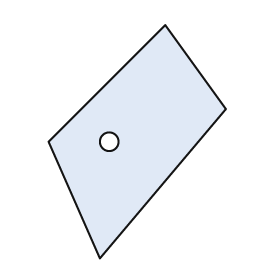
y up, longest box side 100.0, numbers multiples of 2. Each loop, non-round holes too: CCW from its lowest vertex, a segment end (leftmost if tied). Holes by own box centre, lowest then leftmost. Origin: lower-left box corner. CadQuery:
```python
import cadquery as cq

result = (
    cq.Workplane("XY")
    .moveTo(22.0, 0.0)
    .lineTo(76.0, 64.0)
    .lineTo(50.0, 100.0)
    .lineTo(0.0, 50.0)
    .close()
    .moveTo(26.0, 50.0)
    .circle(4.0)
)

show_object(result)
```